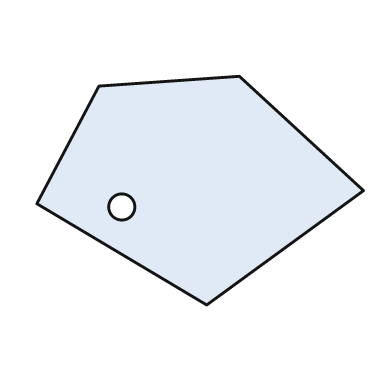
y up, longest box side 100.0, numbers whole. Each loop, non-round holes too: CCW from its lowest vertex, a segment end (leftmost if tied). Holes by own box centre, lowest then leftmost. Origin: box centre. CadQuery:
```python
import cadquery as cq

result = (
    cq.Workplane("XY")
    .moveTo(2.0, -35.0)
    .lineTo(50.0, 0.0)
    .lineTo(12.0, 35.0)
    .lineTo(-31.0, 32.0)
    .lineTo(-50.0, -4.0)
    .close()
    .moveTo(-24.0, -5.0)
    .circle(4.0)
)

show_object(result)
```